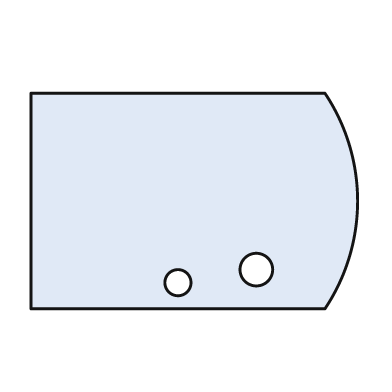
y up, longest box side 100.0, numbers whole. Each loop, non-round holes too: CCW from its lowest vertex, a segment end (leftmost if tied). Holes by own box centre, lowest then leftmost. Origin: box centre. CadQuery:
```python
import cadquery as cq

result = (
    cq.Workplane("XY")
    .moveTo(-50.0, -33.0)
    .lineTo(40.0, -33.0)
    .threePointArc((50.0, 0.0), (40.0, 33.0))
    .lineTo(-50.0, 33.0)
    .close()
    .moveTo(-5.0, -25.0)
    .circle(4.0)
    .moveTo(19.0, -21.0)
    .circle(5.0)
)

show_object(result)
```